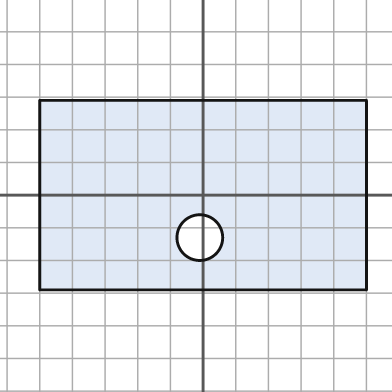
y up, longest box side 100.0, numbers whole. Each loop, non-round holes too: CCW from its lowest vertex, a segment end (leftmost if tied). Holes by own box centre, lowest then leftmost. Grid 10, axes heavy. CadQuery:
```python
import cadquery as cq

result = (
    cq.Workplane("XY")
    .moveTo(-50.0, -29.0)
    .lineTo(50.0, -29.0)
    .lineTo(50.0, 29.0)
    .lineTo(-50.0, 29.0)
    .close()
    .moveTo(-1.0, -13.0)
    .circle(7.0)
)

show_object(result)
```